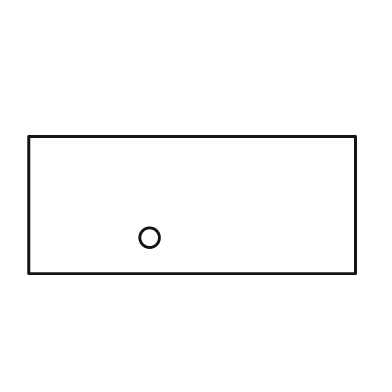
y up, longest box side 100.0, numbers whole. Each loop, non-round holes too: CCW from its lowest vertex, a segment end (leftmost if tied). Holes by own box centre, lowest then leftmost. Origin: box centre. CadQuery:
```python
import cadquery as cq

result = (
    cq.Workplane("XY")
    .moveTo(-50.0, -21.0)
    .lineTo(50.0, -21.0)
    .lineTo(50.0, 21.0)
    .lineTo(-50.0, 21.0)
    .close()
    .moveTo(-13.0, -10.0)
    .circle(3.0)
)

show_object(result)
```